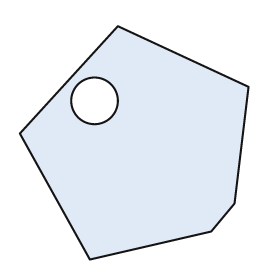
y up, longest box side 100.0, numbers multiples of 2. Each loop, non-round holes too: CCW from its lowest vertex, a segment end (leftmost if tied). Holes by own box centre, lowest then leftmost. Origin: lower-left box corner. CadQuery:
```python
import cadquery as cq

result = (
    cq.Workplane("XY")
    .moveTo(30.0, 0.0)
    .lineTo(82.0, 12.0)
    .lineTo(92.0, 24.0)
    .lineTo(98.0, 74.0)
    .lineTo(42.0, 100.0)
    .lineTo(0.0, 54.0)
    .close()
    .moveTo(32.0, 68.0)
    .circle(10.0)
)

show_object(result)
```